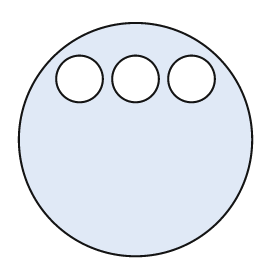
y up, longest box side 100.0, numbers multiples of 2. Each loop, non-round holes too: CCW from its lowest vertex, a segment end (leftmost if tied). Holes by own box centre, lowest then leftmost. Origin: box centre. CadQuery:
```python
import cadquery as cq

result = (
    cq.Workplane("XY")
    .moveTo(0.0, 0.0)
    .circle(50.0)
    .moveTo(-24.0, 26.0)
    .circle(10.0)
    .moveTo(0.0, 26.0)
    .circle(10.0)
    .moveTo(24.0, 26.0)
    .circle(10.0)
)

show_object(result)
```